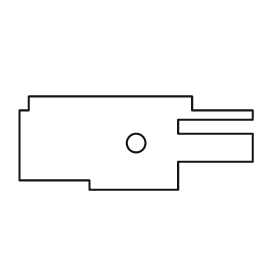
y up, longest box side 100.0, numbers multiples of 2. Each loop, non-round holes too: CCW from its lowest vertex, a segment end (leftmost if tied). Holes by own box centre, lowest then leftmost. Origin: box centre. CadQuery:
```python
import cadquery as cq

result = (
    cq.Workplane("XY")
    .moveTo(-20.0, -20.0)
    .lineTo(18.0, -20.0)
    .lineTo(18.0, -8.0)
    .lineTo(50.0, -8.0)
    .lineTo(50.0, 4.0)
    .lineTo(18.0, 4.0)
    .lineTo(18.0, 10.0)
    .lineTo(50.0, 10.0)
    .lineTo(50.0, 14.0)
    .lineTo(24.0, 14.0)
    .lineTo(24.0, 20.0)
    .lineTo(-46.0, 20.0)
    .lineTo(-46.0, 14.0)
    .lineTo(-50.0, 14.0)
    .lineTo(-50.0, -16.0)
    .lineTo(-20.0, -16.0)
    .close()
    .moveTo(0.0, 0.0)
    .circle(4.0)
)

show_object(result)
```